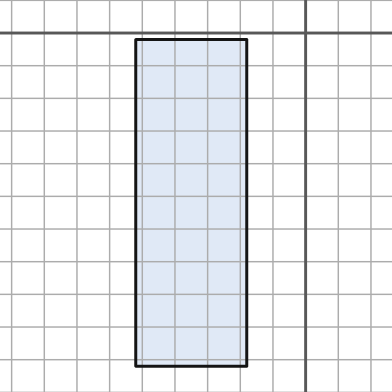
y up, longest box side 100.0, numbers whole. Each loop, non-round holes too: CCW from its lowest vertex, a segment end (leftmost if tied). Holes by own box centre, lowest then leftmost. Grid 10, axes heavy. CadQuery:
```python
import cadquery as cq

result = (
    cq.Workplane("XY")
    .moveTo(-52.0, -102.0)
    .lineTo(-18.0, -102.0)
    .lineTo(-18.0, -2.0)
    .lineTo(-52.0, -2.0)
    .close()
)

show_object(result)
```